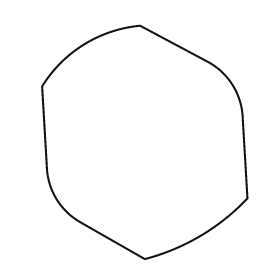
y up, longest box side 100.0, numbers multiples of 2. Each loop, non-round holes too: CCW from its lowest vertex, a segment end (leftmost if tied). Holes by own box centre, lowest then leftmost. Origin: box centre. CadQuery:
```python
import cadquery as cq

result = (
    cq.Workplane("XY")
    .moveTo(0.0, -50.0)
    .threePointArc((24.0, -40.0), (44.0, -24.0))
    .lineTo(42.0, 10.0)
    .threePointArc((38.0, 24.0), (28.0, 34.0))
    .lineTo(-2.0, 50.0)
    .threePointArc((-26.0, 42.0), (-44.0, 24.0))
    .lineTo(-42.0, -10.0)
    .threePointArc((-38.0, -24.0), (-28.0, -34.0))
    .close()
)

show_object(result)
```